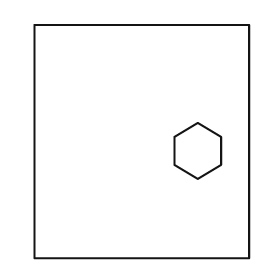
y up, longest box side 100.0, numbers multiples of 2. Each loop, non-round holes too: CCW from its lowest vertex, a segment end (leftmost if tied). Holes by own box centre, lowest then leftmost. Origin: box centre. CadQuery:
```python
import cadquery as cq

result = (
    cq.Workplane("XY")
    .moveTo(-46.0, -50.0)
    .lineTo(46.0, -50.0)
    .lineTo(46.0, 50.0)
    .lineTo(-46.0, 50.0)
    .close()
    .moveTo(24.0, -16.0)
    .lineTo(34.0, -10.0)
    .lineTo(34.0, 2.0)
    .lineTo(24.0, 8.0)
    .lineTo(14.0, 2.0)
    .lineTo(14.0, -10.0)
    .close()
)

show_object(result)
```